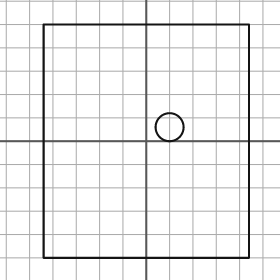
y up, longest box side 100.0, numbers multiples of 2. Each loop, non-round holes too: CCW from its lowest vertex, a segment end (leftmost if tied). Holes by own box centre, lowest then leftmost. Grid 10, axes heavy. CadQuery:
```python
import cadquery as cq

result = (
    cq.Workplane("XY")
    .moveTo(-44.0, -50.0)
    .lineTo(44.0, -50.0)
    .lineTo(44.0, 50.0)
    .lineTo(-44.0, 50.0)
    .close()
    .moveTo(10.0, 6.0)
    .circle(6.0)
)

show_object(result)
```